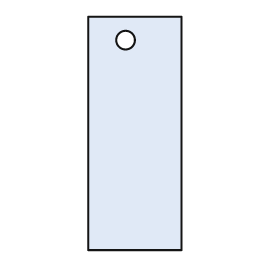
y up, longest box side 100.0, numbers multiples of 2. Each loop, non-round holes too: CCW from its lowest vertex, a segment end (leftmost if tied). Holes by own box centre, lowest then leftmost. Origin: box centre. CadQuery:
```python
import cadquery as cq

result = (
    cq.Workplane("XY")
    .moveTo(-20.0, -50.0)
    .lineTo(20.0, -50.0)
    .lineTo(20.0, 50.0)
    .lineTo(-20.0, 50.0)
    .close()
    .moveTo(-4.0, 40.0)
    .circle(4.0)
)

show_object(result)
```